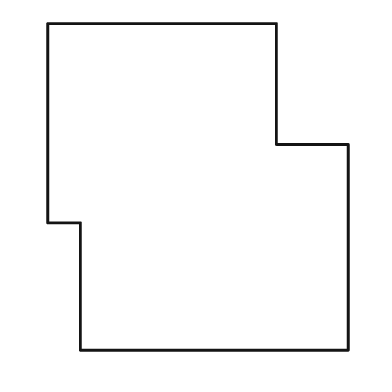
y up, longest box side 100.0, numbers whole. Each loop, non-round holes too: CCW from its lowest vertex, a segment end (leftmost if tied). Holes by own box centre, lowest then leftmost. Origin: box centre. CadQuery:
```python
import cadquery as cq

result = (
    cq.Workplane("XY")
    .moveTo(-36.0, -50.0)
    .lineTo(46.0, -50.0)
    .lineTo(46.0, 13.0)
    .lineTo(24.0, 13.0)
    .lineTo(24.0, 50.0)
    .lineTo(-46.0, 50.0)
    .lineTo(-46.0, -11.0)
    .lineTo(-36.0, -11.0)
    .close()
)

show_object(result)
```